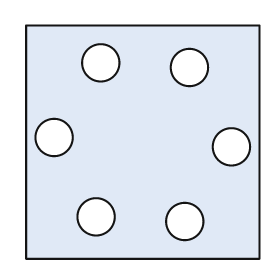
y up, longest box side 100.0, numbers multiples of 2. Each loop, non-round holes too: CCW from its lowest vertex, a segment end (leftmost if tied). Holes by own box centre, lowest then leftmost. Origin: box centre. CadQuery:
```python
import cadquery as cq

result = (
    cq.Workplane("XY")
    .moveTo(-50.0, -50.0)
    .lineTo(50.0, -50.0)
    .lineTo(50.0, 50.0)
    .lineTo(-50.0, 50.0)
    .close()
    .moveTo(18.0, -34.0)
    .circle(8.0)
    .moveTo(-20.0, -32.0)
    .circle(8.0)
    .moveTo(38.0, -2.0)
    .circle(8.0)
    .moveTo(-38.0, 2.0)
    .circle(8.0)
    .moveTo(20.0, 32.0)
    .circle(8.0)
    .moveTo(-18.0, 34.0)
    .circle(8.0)
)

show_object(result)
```